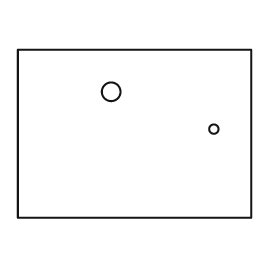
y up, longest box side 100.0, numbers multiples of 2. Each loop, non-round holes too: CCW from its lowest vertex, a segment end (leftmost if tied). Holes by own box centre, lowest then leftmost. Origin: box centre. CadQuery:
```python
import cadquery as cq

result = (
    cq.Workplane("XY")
    .moveTo(-50.0, -36.0)
    .lineTo(50.0, -36.0)
    .lineTo(50.0, 36.0)
    .lineTo(-50.0, 36.0)
    .close()
    .moveTo(34.0, 2.0)
    .circle(2.0)
    .moveTo(-10.0, 18.0)
    .circle(4.0)
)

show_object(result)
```